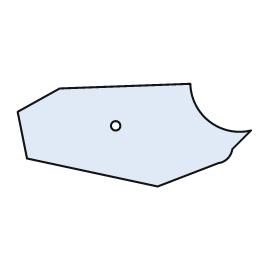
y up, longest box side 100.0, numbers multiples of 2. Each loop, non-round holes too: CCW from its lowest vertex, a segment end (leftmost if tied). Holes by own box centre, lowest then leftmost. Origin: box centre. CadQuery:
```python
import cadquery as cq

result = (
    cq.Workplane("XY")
    .moveTo(10.0, -22.0)
    .lineTo(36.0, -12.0)
    .threePointArc((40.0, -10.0), (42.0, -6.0))
    .lineTo(50.0, 2.0)
    .threePointArc((32.0, 6.0), (24.0, 22.0))
    .lineTo(-32.0, 20.0)
    .lineTo(-50.0, 10.0)
    .lineTo(-46.0, -10.0)
    .close()
    .moveTo(-8.0, 4.0)
    .circle(2.0)
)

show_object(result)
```